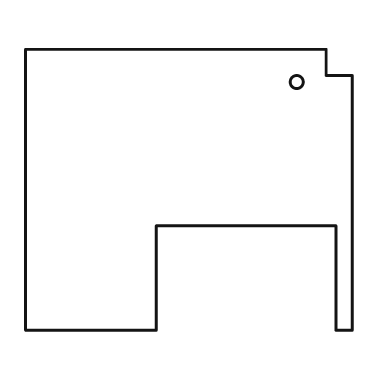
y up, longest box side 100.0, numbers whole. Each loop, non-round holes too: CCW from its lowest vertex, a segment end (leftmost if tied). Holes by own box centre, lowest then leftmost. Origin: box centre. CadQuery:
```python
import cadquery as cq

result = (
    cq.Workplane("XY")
    .moveTo(-50.0, -43.0)
    .lineTo(-10.0, -43.0)
    .lineTo(-10.0, -11.0)
    .lineTo(45.0, -11.0)
    .lineTo(45.0, -43.0)
    .lineTo(50.0, -43.0)
    .lineTo(50.0, 35.0)
    .lineTo(42.0, 35.0)
    .lineTo(42.0, 43.0)
    .lineTo(-50.0, 43.0)
    .close()
    .moveTo(33.0, 33.0)
    .circle(2.0)
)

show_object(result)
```